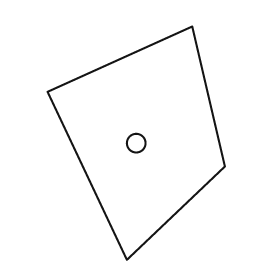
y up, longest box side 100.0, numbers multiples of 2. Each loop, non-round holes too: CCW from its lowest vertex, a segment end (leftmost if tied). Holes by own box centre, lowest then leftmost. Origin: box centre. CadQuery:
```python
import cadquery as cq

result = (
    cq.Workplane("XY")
    .moveTo(-4.0, -50.0)
    .lineTo(38.0, -10.0)
    .lineTo(24.0, 50.0)
    .lineTo(-38.0, 22.0)
    .close()
    .moveTo(0.0, 0.0)
    .circle(4.0)
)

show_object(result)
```